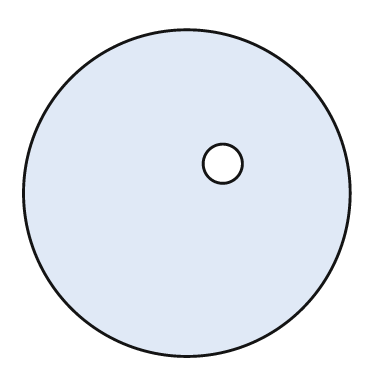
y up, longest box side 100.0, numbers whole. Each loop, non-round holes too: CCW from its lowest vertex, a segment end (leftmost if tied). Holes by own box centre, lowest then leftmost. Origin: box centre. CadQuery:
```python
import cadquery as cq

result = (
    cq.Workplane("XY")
    .moveTo(0.0, 0.0)
    .circle(50.0)
    .moveTo(11.0, 9.0)
    .circle(6.0)
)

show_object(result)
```